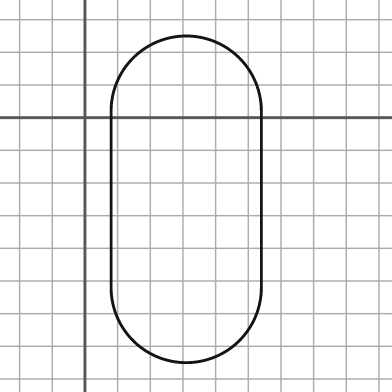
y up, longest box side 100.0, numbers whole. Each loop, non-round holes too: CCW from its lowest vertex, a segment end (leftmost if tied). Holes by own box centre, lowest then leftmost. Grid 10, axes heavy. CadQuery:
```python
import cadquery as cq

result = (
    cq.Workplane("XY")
    .moveTo(8.0, -52.0)
    .threePointArc((31.0, -75.0), (54.0, -52.0))
    .lineTo(54.0, 2.0)
    .threePointArc((31.0, 25.0), (8.0, 2.0))
    .close()
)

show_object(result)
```